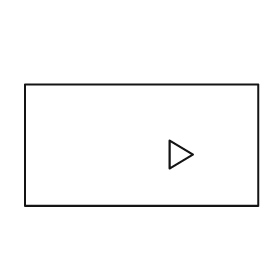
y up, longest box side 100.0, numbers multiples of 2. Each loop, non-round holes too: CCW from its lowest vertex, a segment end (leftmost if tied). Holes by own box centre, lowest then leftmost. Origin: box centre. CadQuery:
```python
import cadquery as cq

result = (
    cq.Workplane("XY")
    .moveTo(-50.0, -26.0)
    .lineTo(50.0, -26.0)
    .lineTo(50.0, 26.0)
    .lineTo(-50.0, 26.0)
    .close()
    .moveTo(12.0, -10.0)
    .lineTo(22.0, -4.0)
    .lineTo(12.0, 2.0)
    .close()
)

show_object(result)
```